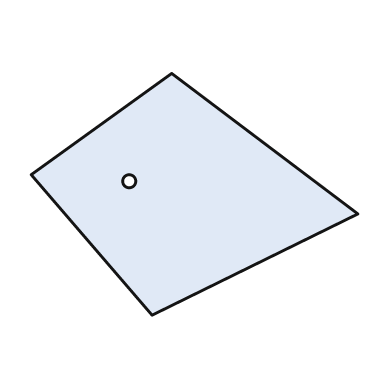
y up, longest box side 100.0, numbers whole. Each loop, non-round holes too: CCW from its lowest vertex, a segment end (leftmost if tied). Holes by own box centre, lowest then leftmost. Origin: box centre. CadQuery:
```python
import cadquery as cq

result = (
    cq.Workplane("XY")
    .moveTo(-13.0, -37.0)
    .lineTo(50.0, -6.0)
    .lineTo(-7.0, 37.0)
    .lineTo(-50.0, 6.0)
    .close()
    .moveTo(-20.0, 4.0)
    .circle(2.0)
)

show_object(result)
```